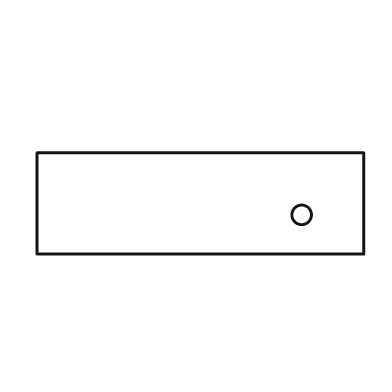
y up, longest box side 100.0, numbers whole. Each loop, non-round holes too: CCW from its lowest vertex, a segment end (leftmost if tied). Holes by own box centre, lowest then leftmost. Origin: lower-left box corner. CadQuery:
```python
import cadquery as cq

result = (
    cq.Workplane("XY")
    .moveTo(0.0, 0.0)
    .lineTo(100.0, 0.0)
    .lineTo(100.0, 31.0)
    .lineTo(0.0, 31.0)
    .close()
    .moveTo(81.0, 12.0)
    .circle(3.0)
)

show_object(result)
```